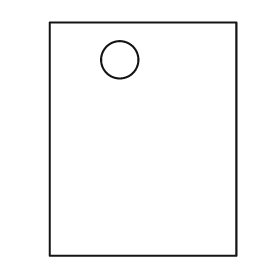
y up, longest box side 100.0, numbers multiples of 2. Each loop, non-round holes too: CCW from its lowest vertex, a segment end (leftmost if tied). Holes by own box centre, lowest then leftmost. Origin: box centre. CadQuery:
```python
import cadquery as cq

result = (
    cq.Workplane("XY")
    .moveTo(-40.0, -50.0)
    .lineTo(40.0, -50.0)
    .lineTo(40.0, 50.0)
    .lineTo(-40.0, 50.0)
    .close()
    .moveTo(-10.0, 34.0)
    .circle(8.0)
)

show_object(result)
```